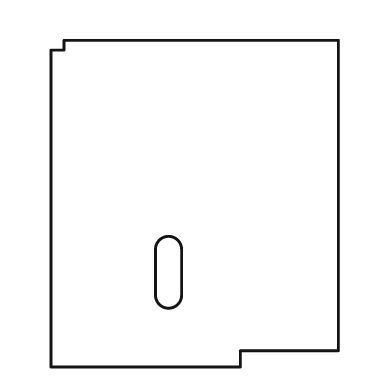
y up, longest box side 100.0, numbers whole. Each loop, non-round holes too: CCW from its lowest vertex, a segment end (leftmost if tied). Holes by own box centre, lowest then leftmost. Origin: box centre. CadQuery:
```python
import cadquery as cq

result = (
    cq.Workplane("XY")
    .moveTo(-44.0, -50.0)
    .lineTo(14.0, -50.0)
    .lineTo(14.0, -45.0)
    .lineTo(44.0, -45.0)
    .lineTo(44.0, 50.0)
    .lineTo(-40.0, 50.0)
    .lineTo(-40.0, 47.0)
    .lineTo(-44.0, 47.0)
    .close()
    .moveTo(-12.0, -28.0)
    .threePointArc((-8.0, -32.0), (-4.0, -28.0))
    .lineTo(-4.0, -14.0)
    .threePointArc((-8.0, -10.0), (-12.0, -14.0))
    .close()
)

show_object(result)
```